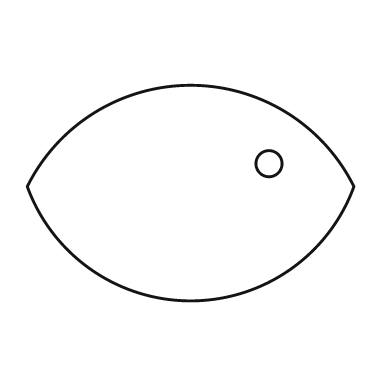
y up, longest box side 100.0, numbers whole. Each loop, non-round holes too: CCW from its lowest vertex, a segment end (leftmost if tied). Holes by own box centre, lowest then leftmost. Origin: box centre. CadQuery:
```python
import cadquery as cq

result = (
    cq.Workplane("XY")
    .moveTo(-50.0, 2.0)
    .threePointArc((0.0, -33.0), (50.0, 2.0))
    .threePointArc((0.0, 33.0), (-50.0, 2.0))
    .close()
    .moveTo(24.0, 9.0)
    .circle(4.0)
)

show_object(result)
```